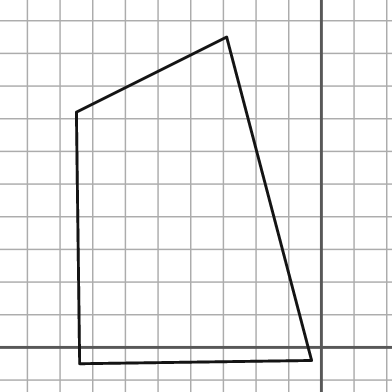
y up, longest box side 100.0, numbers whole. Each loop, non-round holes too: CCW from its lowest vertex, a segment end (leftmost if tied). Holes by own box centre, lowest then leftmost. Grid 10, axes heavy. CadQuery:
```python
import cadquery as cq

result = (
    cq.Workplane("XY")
    .moveTo(-74.0, -5.0)
    .lineTo(-3.0, -4.0)
    .lineTo(-29.0, 95.0)
    .lineTo(-75.0, 72.0)
    .close()
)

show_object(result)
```